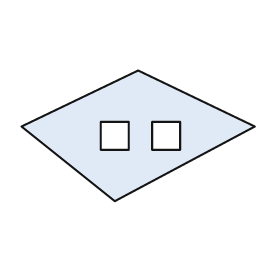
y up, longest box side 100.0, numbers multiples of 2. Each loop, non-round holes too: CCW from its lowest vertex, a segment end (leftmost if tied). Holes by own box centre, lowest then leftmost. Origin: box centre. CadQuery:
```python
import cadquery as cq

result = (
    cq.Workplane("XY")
    .moveTo(-10.0, -28.0)
    .lineTo(50.0, 4.0)
    .lineTo(0.0, 28.0)
    .lineTo(-50.0, 4.0)
    .close()
    .moveTo(-16.0, -6.0)
    .lineTo(-4.0, -6.0)
    .lineTo(-4.0, 6.0)
    .lineTo(-16.0, 6.0)
    .close()
    .moveTo(6.0, -6.0)
    .lineTo(18.0, -6.0)
    .lineTo(18.0, 6.0)
    .lineTo(6.0, 6.0)
    .close()
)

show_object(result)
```